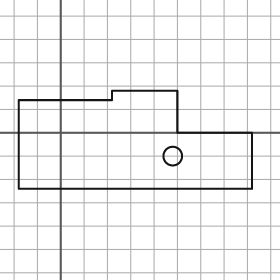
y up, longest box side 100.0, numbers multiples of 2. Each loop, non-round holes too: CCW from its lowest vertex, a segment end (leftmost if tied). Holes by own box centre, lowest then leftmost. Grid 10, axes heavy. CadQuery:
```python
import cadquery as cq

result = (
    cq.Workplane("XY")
    .moveTo(-18.0, -24.0)
    .lineTo(82.0, -24.0)
    .lineTo(82.0, 0.0)
    .lineTo(50.0, 0.0)
    .lineTo(50.0, 18.0)
    .lineTo(22.0, 18.0)
    .lineTo(22.0, 14.0)
    .lineTo(-18.0, 14.0)
    .close()
    .moveTo(48.0, -10.0)
    .circle(4.0)
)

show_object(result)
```